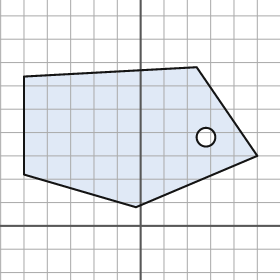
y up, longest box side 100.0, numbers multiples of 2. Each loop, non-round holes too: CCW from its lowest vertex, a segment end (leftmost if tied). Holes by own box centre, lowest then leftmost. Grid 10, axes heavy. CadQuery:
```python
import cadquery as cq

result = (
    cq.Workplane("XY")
    .moveTo(-2.0, 8.0)
    .lineTo(50.0, 30.0)
    .lineTo(24.0, 68.0)
    .lineTo(-50.0, 64.0)
    .lineTo(-50.0, 22.0)
    .close()
    .moveTo(28.0, 38.0)
    .circle(4.0)
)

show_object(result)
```